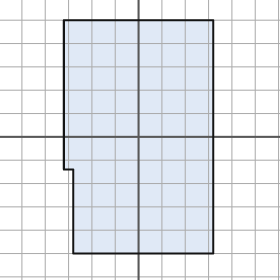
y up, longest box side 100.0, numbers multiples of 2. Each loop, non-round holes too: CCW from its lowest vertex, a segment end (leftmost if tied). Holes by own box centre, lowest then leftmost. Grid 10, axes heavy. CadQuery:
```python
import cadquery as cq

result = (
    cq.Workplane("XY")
    .moveTo(-28.0, -50.0)
    .lineTo(32.0, -50.0)
    .lineTo(32.0, 50.0)
    .lineTo(-32.0, 50.0)
    .lineTo(-32.0, -14.0)
    .lineTo(-28.0, -14.0)
    .close()
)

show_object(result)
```